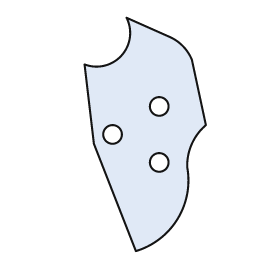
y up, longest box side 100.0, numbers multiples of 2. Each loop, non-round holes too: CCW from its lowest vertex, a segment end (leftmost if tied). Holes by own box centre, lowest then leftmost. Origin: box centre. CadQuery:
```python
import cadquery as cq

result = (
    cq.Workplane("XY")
    .moveTo(-4.0, -50.0)
    .threePointArc((14.0, -36.0), (18.0, -14.0))
    .threePointArc((20.0, -4.0), (26.0, 4.0))
    .lineTo(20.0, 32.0)
    .threePointArc((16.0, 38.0), (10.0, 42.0))
    .lineTo(-8.0, 50.0)
    .threePointArc((-10.0, 34.0), (-26.0, 30.0))
    .lineTo(-22.0, -4.0)
    .close()
    .moveTo(6.0, -12.0)
    .circle(4.0)
    .moveTo(-14.0, 0.0)
    .circle(4.0)
    .moveTo(6.0, 12.0)
    .circle(4.0)
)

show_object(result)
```